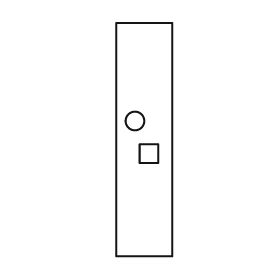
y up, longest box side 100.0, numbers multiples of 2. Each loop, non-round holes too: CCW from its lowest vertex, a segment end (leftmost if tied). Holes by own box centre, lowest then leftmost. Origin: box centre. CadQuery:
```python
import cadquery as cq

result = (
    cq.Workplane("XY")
    .moveTo(-12.0, -50.0)
    .lineTo(12.0, -50.0)
    .lineTo(12.0, 50.0)
    .lineTo(-12.0, 50.0)
    .close()
    .moveTo(-2.0, -10.0)
    .lineTo(6.0, -10.0)
    .lineTo(6.0, -2.0)
    .lineTo(-2.0, -2.0)
    .close()
    .moveTo(-4.0, 8.0)
    .circle(4.0)
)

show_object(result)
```